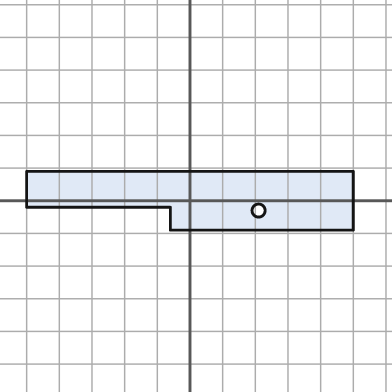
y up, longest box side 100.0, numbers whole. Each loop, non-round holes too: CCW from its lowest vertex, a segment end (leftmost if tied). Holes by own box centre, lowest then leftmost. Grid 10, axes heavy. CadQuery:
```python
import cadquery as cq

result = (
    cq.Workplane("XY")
    .moveTo(-6.0, -9.0)
    .lineTo(50.0, -9.0)
    .lineTo(50.0, 9.0)
    .lineTo(-50.0, 9.0)
    .lineTo(-50.0, -2.0)
    .lineTo(-6.0, -2.0)
    .close()
    .moveTo(21.0, -3.0)
    .circle(2.0)
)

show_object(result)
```